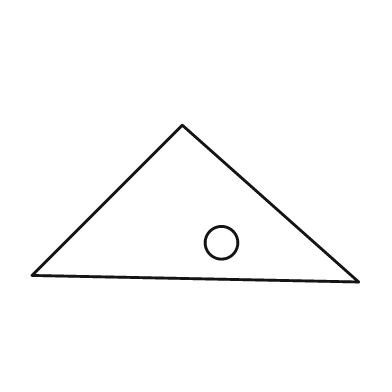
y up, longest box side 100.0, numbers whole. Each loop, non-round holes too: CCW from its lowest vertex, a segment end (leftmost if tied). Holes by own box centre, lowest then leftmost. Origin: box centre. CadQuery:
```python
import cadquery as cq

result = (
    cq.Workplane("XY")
    .moveTo(50.0, -24.0)
    .lineTo(-4.0, 24.0)
    .lineTo(-50.0, -22.0)
    .close()
    .moveTo(8.0, -12.0)
    .circle(5.0)
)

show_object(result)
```